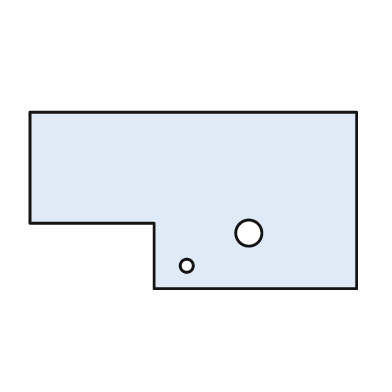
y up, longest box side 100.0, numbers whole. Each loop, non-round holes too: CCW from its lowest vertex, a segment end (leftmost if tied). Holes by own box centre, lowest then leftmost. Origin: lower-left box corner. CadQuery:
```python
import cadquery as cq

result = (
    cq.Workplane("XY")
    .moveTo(38.0, 0.0)
    .lineTo(100.0, 0.0)
    .lineTo(100.0, 54.0)
    .lineTo(0.0, 54.0)
    .lineTo(0.0, 20.0)
    .lineTo(38.0, 20.0)
    .close()
    .moveTo(48.0, 7.0)
    .circle(2.0)
    .moveTo(67.0, 17.0)
    .circle(4.0)
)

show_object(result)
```